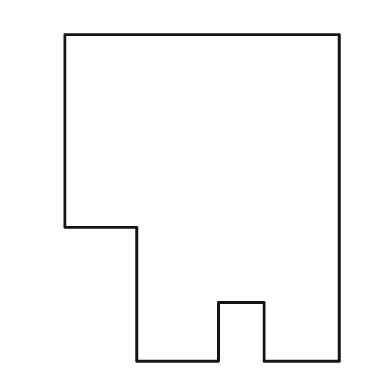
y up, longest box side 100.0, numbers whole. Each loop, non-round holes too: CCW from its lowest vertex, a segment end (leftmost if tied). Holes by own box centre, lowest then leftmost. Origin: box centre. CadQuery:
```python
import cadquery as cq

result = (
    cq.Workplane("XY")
    .moveTo(-20.0, -50.0)
    .lineTo(5.0, -50.0)
    .lineTo(5.0, -32.0)
    .lineTo(19.0, -32.0)
    .lineTo(19.0, -50.0)
    .lineTo(42.0, -50.0)
    .lineTo(42.0, 50.0)
    .lineTo(-42.0, 50.0)
    .lineTo(-42.0, -9.0)
    .lineTo(-20.0, -9.0)
    .close()
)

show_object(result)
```